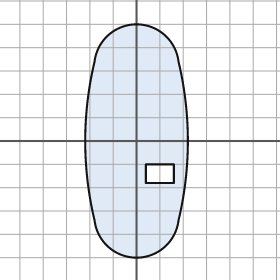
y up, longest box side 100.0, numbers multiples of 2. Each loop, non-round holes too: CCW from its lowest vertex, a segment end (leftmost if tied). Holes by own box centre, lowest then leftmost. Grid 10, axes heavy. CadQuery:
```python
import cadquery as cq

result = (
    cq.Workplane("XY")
    .moveTo(-18.0, -34.0)
    .threePointArc((0.0, -50.0), (18.0, -34.0))
    .threePointArc((22.0, 0.0), (18.0, 34.0))
    .threePointArc((0.0, 50.0), (-18.0, 34.0))
    .threePointArc((-22.0, 0.0), (-18.0, -34.0))
    .close()
    .moveTo(4.0, -18.0)
    .lineTo(16.0, -18.0)
    .lineTo(16.0, -10.0)
    .lineTo(4.0, -10.0)
    .close()
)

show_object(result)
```